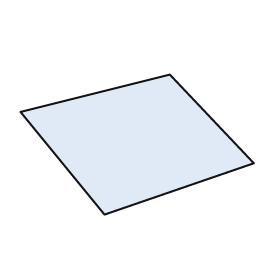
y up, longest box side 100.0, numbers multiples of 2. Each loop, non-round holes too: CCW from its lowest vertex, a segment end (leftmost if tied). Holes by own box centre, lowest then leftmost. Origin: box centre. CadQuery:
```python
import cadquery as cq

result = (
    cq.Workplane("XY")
    .moveTo(-14.0, -30.0)
    .lineTo(50.0, -8.0)
    .lineTo(14.0, 30.0)
    .lineTo(-50.0, 14.0)
    .close()
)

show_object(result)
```